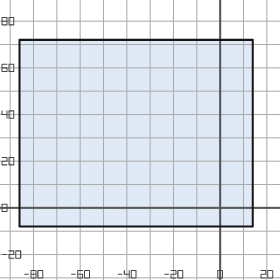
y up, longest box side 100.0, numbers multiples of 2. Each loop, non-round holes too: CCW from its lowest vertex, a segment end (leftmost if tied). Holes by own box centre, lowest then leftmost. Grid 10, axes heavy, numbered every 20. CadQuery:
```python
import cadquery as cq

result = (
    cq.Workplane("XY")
    .moveTo(-86.0, -8.0)
    .lineTo(14.0, -8.0)
    .lineTo(14.0, 72.0)
    .lineTo(-86.0, 72.0)
    .close()
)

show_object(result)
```